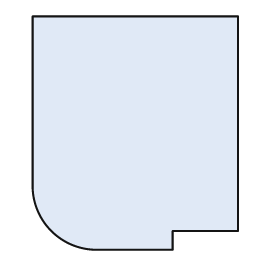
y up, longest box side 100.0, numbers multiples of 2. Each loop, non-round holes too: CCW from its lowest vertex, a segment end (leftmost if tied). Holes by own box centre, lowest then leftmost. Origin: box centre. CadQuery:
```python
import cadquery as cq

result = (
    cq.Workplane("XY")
    .moveTo(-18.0, -50.0)
    .lineTo(16.0, -50.0)
    .lineTo(16.0, -42.0)
    .lineTo(44.0, -42.0)
    .lineTo(44.0, 50.0)
    .lineTo(-44.0, 50.0)
    .lineTo(-44.0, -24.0)
    .threePointArc((-36.0, -42.0), (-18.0, -50.0))
    .close()
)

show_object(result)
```